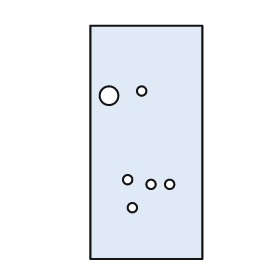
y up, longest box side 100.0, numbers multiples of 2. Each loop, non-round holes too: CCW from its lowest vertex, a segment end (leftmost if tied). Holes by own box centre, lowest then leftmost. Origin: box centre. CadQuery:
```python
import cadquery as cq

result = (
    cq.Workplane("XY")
    .moveTo(-24.0, -50.0)
    .lineTo(24.0, -50.0)
    .lineTo(24.0, 50.0)
    .lineTo(-24.0, 50.0)
    .close()
    .moveTo(-6.0, -28.0)
    .circle(2.0)
    .moveTo(2.0, -18.0)
    .circle(2.0)
    .moveTo(10.0, -18.0)
    .circle(2.0)
    .moveTo(-8.0, -16.0)
    .circle(2.0)
    .moveTo(-16.0, 20.0)
    .circle(4.0)
    .moveTo(-2.0, 22.0)
    .circle(2.0)
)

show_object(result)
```